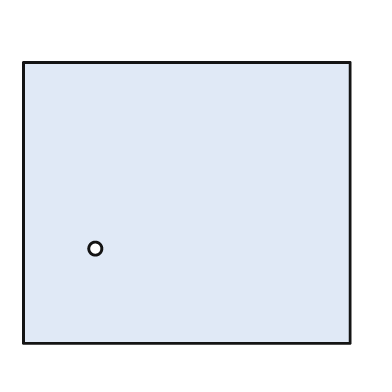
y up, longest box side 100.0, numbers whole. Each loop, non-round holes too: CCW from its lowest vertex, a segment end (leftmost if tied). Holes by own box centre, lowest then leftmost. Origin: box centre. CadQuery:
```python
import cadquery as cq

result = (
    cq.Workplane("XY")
    .moveTo(-50.0, -43.0)
    .lineTo(50.0, -43.0)
    .lineTo(50.0, 43.0)
    .lineTo(-50.0, 43.0)
    .close()
    .moveTo(-28.0, -14.0)
    .circle(2.0)
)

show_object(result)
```